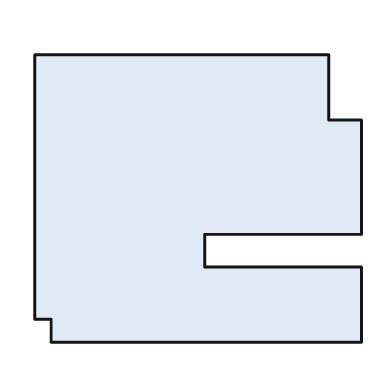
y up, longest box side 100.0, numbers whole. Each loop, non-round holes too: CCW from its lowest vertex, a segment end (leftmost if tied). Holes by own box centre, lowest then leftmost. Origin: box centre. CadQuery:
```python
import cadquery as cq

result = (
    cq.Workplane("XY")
    .moveTo(-45.0, -44.0)
    .lineTo(50.0, -44.0)
    .lineTo(50.0, -21.0)
    .lineTo(2.0, -21.0)
    .lineTo(2.0, -11.0)
    .lineTo(50.0, -11.0)
    .lineTo(50.0, 24.0)
    .lineTo(40.0, 24.0)
    .lineTo(40.0, 44.0)
    .lineTo(-50.0, 44.0)
    .lineTo(-50.0, -37.0)
    .lineTo(-45.0, -37.0)
    .close()
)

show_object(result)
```